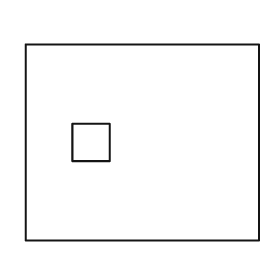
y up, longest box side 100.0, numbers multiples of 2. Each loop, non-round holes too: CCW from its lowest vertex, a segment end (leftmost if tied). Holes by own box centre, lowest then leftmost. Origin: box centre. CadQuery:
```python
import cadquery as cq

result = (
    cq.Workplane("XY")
    .moveTo(-50.0, -42.0)
    .lineTo(50.0, -42.0)
    .lineTo(50.0, 42.0)
    .lineTo(-50.0, 42.0)
    .close()
    .moveTo(-30.0, -8.0)
    .lineTo(-14.0, -8.0)
    .lineTo(-14.0, 8.0)
    .lineTo(-30.0, 8.0)
    .close()
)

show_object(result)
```